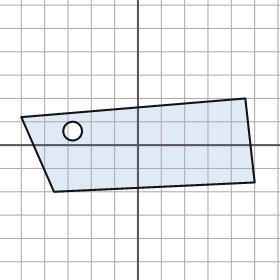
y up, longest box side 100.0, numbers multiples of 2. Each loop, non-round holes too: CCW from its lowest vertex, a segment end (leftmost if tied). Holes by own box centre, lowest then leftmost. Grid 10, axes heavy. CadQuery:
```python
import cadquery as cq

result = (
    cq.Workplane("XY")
    .moveTo(-36.0, -20.0)
    .lineTo(50.0, -16.0)
    .lineTo(46.0, 20.0)
    .lineTo(-50.0, 12.0)
    .close()
    .moveTo(-28.0, 6.0)
    .circle(4.0)
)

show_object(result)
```